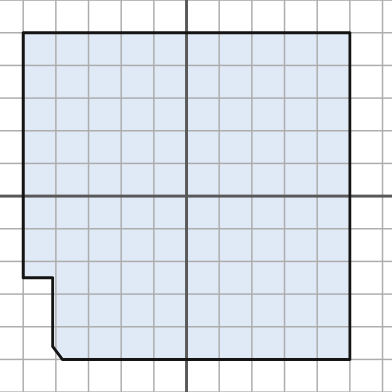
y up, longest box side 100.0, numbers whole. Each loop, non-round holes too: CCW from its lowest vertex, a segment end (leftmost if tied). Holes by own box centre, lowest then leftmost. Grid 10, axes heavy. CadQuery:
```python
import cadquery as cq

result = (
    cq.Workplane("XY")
    .moveTo(-38.0, -50.0)
    .lineTo(50.0, -50.0)
    .lineTo(50.0, 50.0)
    .lineTo(-50.0, 50.0)
    .lineTo(-50.0, -25.0)
    .lineTo(-41.0, -25.0)
    .lineTo(-41.0, -46.0)
    .close()
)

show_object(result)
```